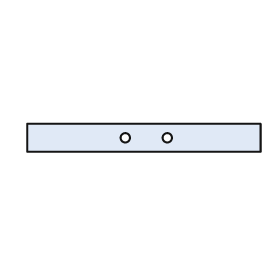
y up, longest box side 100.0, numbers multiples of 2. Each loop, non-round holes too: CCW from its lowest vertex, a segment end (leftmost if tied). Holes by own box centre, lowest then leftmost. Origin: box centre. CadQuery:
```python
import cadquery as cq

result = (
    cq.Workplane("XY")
    .moveTo(-50.0, -6.0)
    .lineTo(50.0, -6.0)
    .lineTo(50.0, 6.0)
    .lineTo(-50.0, 6.0)
    .close()
    .moveTo(-8.0, 0.0)
    .circle(2.0)
    .moveTo(10.0, 0.0)
    .circle(2.0)
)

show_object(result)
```